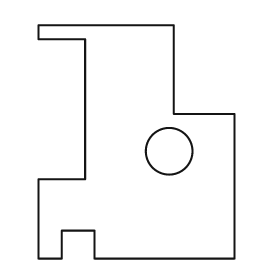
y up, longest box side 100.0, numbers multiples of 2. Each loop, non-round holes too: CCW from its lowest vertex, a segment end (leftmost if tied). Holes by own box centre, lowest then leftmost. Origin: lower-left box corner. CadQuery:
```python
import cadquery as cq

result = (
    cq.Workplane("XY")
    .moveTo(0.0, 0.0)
    .lineTo(10.0, 0.0)
    .lineTo(10.0, 12.0)
    .lineTo(24.0, 12.0)
    .lineTo(24.0, 0.0)
    .lineTo(84.0, 0.0)
    .lineTo(84.0, 62.0)
    .lineTo(58.0, 62.0)
    .lineTo(58.0, 100.0)
    .lineTo(0.0, 100.0)
    .lineTo(0.0, 94.0)
    .lineTo(20.0, 94.0)
    .lineTo(20.0, 34.0)
    .lineTo(0.0, 34.0)
    .close()
    .moveTo(56.0, 46.0)
    .circle(10.0)
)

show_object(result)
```